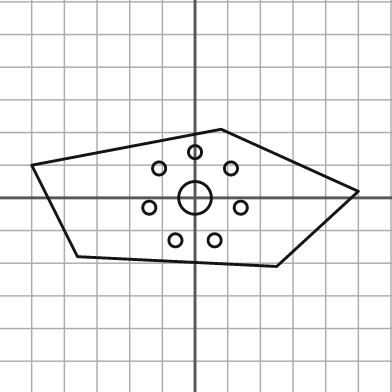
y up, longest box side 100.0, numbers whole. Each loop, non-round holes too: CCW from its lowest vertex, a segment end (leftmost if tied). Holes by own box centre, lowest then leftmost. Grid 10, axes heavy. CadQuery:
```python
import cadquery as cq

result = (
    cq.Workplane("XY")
    .moveTo(25.0, -21.0)
    .lineTo(50.0, 2.0)
    .lineTo(8.0, 21.0)
    .lineTo(-50.0, 10.0)
    .lineTo(-36.0, -18.0)
    .close()
    .moveTo(-6.0, -13.0)
    .circle(2.0)
    .moveTo(6.0, -13.0)
    .circle(2.0)
    .moveTo(-14.0, -3.0)
    .circle(2.0)
    .moveTo(14.0, -3.0)
    .circle(2.0)
    .moveTo(0.0, 0.0)
    .circle(5.0)
    .moveTo(-11.0, 9.0)
    .circle(2.0)
    .moveTo(11.0, 9.0)
    .circle(2.0)
    .moveTo(0.0, 14.0)
    .circle(2.0)
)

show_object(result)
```